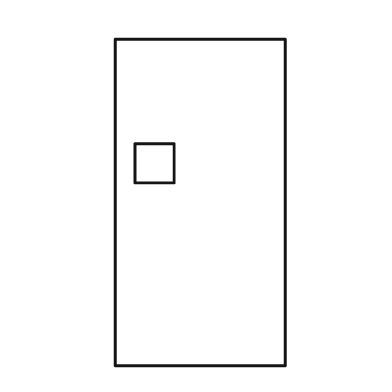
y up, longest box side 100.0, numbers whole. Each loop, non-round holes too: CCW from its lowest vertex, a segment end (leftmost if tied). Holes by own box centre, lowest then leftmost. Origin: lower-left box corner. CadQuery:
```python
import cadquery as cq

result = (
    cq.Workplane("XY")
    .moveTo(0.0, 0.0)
    .lineTo(52.0, 0.0)
    .lineTo(52.0, 100.0)
    .lineTo(0.0, 100.0)
    .close()
    .moveTo(6.0, 56.0)
    .lineTo(18.0, 56.0)
    .lineTo(18.0, 68.0)
    .lineTo(6.0, 68.0)
    .close()
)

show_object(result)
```